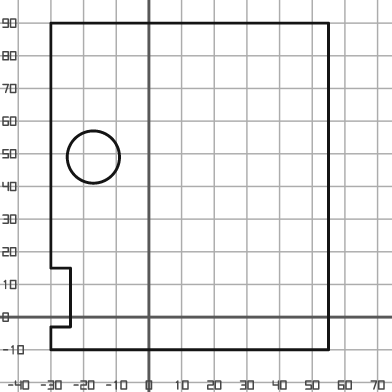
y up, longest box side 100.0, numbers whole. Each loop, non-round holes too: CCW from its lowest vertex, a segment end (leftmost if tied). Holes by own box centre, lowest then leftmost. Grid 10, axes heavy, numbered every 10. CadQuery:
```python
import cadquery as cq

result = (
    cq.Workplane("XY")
    .moveTo(-30.0, -10.0)
    .lineTo(55.0, -10.0)
    .lineTo(55.0, 90.0)
    .lineTo(-30.0, 90.0)
    .lineTo(-30.0, 15.0)
    .lineTo(-24.0, 15.0)
    .lineTo(-24.0, -3.0)
    .lineTo(-30.0, -3.0)
    .close()
    .moveTo(-17.0, 49.0)
    .circle(8.0)
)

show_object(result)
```